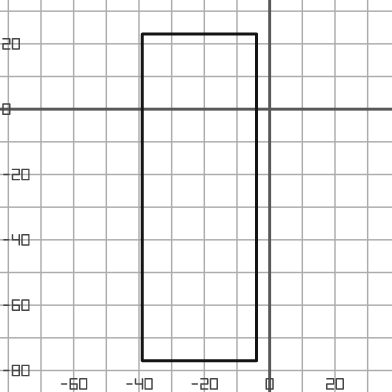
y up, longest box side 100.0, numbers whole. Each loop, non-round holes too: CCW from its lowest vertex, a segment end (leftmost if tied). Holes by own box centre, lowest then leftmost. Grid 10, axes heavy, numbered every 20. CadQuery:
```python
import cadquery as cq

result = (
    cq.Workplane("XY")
    .moveTo(-39.0, -77.0)
    .lineTo(-4.0, -77.0)
    .lineTo(-4.0, 23.0)
    .lineTo(-39.0, 23.0)
    .close()
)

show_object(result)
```